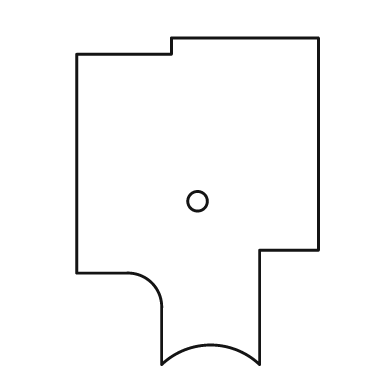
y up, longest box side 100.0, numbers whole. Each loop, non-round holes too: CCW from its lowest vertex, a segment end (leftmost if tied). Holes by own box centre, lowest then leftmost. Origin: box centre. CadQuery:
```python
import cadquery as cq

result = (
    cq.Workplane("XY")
    .moveTo(-11.0, -50.0)
    .threePointArc((4.0, -44.0), (19.0, -50.0))
    .lineTo(19.0, -15.0)
    .lineTo(37.0, -15.0)
    .lineTo(37.0, 50.0)
    .lineTo(-8.0, 50.0)
    .lineTo(-8.0, 45.0)
    .lineTo(-37.0, 45.0)
    .lineTo(-37.0, -22.0)
    .lineTo(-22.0, -22.0)
    .threePointArc((-14.0, -25.0), (-11.0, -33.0))
    .close()
    .moveTo(0.0, 0.0)
    .circle(3.0)
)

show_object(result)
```